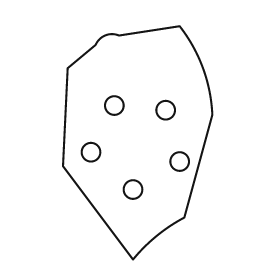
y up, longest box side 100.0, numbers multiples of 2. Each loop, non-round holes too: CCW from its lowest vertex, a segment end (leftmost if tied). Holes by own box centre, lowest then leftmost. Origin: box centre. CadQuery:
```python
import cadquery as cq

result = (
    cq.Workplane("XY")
    .moveTo(-2.0, -50.0)
    .threePointArc((8.0, -40.0), (20.0, -32.0))
    .lineTo(32.0, 12.0)
    .threePointArc((28.0, 32.0), (18.0, 50.0))
    .lineTo(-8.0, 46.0)
    .threePointArc((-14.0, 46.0), (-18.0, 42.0))
    .lineTo(-30.0, 32.0)
    .lineTo(-32.0, -10.0)
    .close()
    .moveTo(-2.0, -20.0)
    .circle(4.0)
    .moveTo(18.0, -8.0)
    .circle(4.0)
    .moveTo(-20.0, -4.0)
    .circle(4.0)
    .moveTo(12.0, 14.0)
    .circle(4.0)
    .moveTo(-10.0, 16.0)
    .circle(4.0)
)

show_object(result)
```